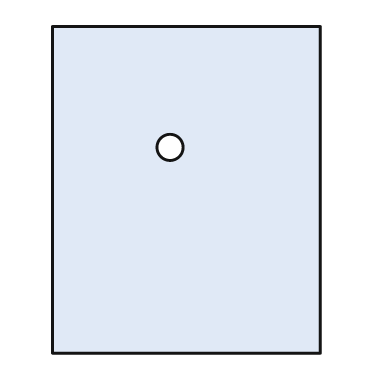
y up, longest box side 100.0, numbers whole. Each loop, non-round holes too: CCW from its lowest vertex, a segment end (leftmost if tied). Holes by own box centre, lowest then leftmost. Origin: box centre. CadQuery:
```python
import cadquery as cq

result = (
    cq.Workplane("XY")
    .moveTo(-41.0, -50.0)
    .lineTo(41.0, -50.0)
    .lineTo(41.0, 50.0)
    .lineTo(-41.0, 50.0)
    .close()
    .moveTo(-5.0, 13.0)
    .circle(4.0)
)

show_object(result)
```